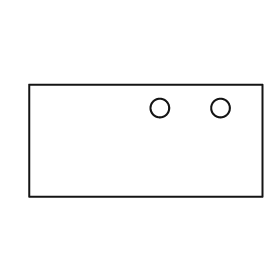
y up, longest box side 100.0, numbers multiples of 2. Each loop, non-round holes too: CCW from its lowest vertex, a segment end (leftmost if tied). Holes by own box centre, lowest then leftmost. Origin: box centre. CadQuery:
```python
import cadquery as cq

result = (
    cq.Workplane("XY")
    .moveTo(-50.0, -24.0)
    .lineTo(50.0, -24.0)
    .lineTo(50.0, 24.0)
    .lineTo(-50.0, 24.0)
    .close()
    .moveTo(6.0, 14.0)
    .circle(4.0)
    .moveTo(32.0, 14.0)
    .circle(4.0)
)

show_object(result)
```